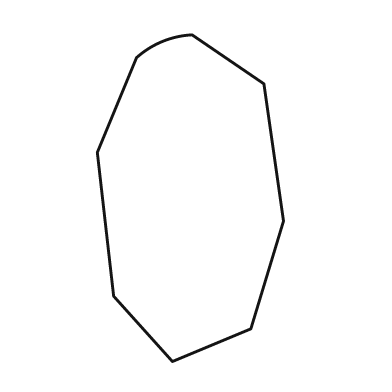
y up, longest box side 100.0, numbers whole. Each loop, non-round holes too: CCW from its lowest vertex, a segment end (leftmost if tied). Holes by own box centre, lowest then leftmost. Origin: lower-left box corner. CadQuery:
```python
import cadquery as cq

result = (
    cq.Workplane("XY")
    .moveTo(23.0, 0.0)
    .lineTo(47.0, 10.0)
    .lineTo(57.0, 43.0)
    .lineTo(51.0, 85.0)
    .lineTo(29.0, 100.0)
    .threePointArc((20.0, 98.0), (12.0, 93.0))
    .lineTo(0.0, 64.0)
    .lineTo(5.0, 20.0)
    .close()
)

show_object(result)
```